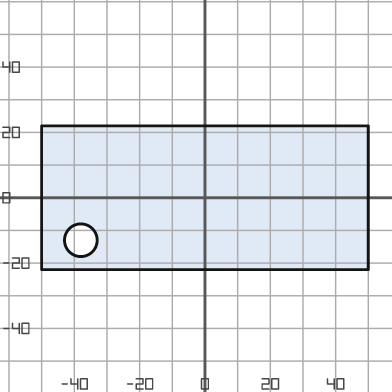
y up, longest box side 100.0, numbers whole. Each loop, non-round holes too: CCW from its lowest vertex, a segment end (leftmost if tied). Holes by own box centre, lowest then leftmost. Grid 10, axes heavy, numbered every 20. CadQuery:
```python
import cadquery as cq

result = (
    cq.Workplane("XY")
    .moveTo(-50.0, -22.0)
    .lineTo(50.0, -22.0)
    .lineTo(50.0, 22.0)
    .lineTo(-50.0, 22.0)
    .close()
    .moveTo(-38.0, -13.0)
    .circle(5.0)
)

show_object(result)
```